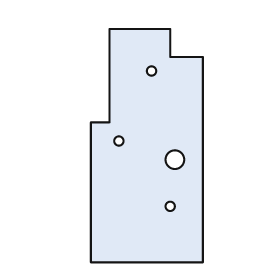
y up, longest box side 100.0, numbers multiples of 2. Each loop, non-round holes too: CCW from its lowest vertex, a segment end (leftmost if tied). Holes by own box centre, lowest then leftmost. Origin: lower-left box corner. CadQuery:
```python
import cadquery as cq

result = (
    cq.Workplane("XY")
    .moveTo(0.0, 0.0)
    .lineTo(48.0, 0.0)
    .lineTo(48.0, 88.0)
    .lineTo(34.0, 88.0)
    .lineTo(34.0, 100.0)
    .lineTo(8.0, 100.0)
    .lineTo(8.0, 60.0)
    .lineTo(0.0, 60.0)
    .close()
    .moveTo(34.0, 24.0)
    .circle(2.0)
    .moveTo(36.0, 44.0)
    .circle(4.0)
    .moveTo(12.0, 52.0)
    .circle(2.0)
    .moveTo(26.0, 82.0)
    .circle(2.0)
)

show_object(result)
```